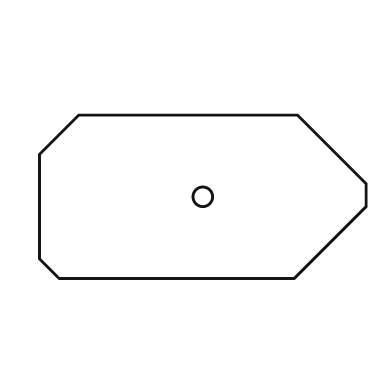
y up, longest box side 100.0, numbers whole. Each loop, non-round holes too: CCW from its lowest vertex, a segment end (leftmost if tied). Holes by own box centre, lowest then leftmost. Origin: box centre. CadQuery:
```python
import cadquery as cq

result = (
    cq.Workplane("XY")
    .moveTo(-44.0, -25.0)
    .lineTo(28.0, -25.0)
    .lineTo(50.0, -3.0)
    .lineTo(50.0, 4.0)
    .lineTo(29.0, 25.0)
    .lineTo(-38.0, 25.0)
    .lineTo(-50.0, 13.0)
    .lineTo(-50.0, -19.0)
    .close()
    .moveTo(0.0, 0.0)
    .circle(3.0)
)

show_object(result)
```